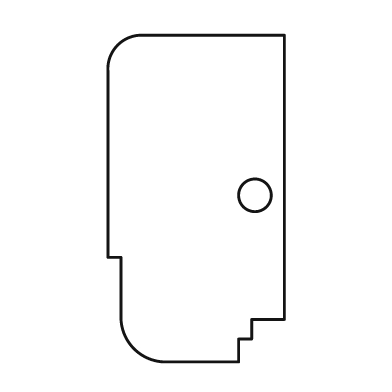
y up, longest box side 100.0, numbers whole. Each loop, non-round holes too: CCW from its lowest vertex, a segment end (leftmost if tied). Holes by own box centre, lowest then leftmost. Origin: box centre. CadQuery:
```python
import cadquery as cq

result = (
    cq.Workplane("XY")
    .moveTo(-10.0, -50.0)
    .lineTo(13.0, -50.0)
    .lineTo(13.0, -43.0)
    .lineTo(17.0, -43.0)
    .lineTo(17.0, -37.0)
    .lineTo(27.0, -37.0)
    .lineTo(27.0, 50.0)
    .lineTo(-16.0, 50.0)
    .threePointArc((-24.0, 47.0), (-27.0, 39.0))
    .lineTo(-27.0, -18.0)
    .lineTo(-23.0, -18.0)
    .lineTo(-23.0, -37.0)
    .threePointArc((-19.0, -46.0), (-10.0, -50.0))
    .close()
    .moveTo(18.0, 1.0)
    .circle(5.0)
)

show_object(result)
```